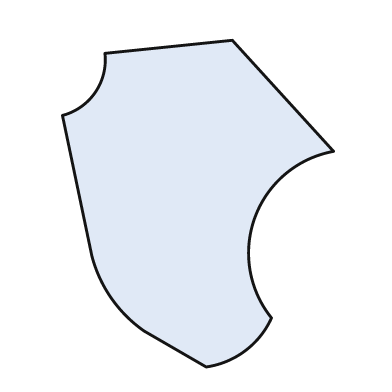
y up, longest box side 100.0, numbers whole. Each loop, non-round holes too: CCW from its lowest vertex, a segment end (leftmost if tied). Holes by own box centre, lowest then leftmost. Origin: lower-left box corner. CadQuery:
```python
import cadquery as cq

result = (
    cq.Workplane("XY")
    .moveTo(44.0, 0.0)
    .threePointArc((56.0, 5.0), (64.0, 15.0))
    .threePointArc((59.0, 46.0), (83.0, 66.0))
    .lineTo(52.0, 100.0)
    .lineTo(13.0, 96.0)
    .threePointArc((10.0, 84.0), (0.0, 77.0))
    .lineTo(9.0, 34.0)
    .threePointArc((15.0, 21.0), (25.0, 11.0))
    .close()
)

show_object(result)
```